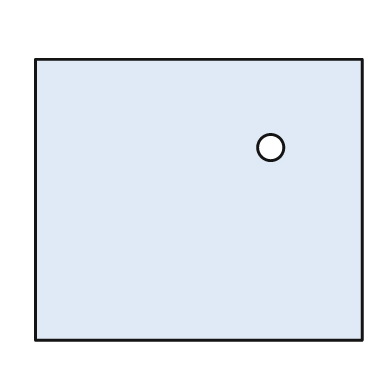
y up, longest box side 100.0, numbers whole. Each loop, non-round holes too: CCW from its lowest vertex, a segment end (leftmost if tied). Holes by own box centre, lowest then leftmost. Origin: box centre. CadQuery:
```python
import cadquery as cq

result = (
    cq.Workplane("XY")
    .moveTo(-50.0, -43.0)
    .lineTo(50.0, -43.0)
    .lineTo(50.0, 43.0)
    .lineTo(-50.0, 43.0)
    .close()
    .moveTo(22.0, 16.0)
    .circle(4.0)
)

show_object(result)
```